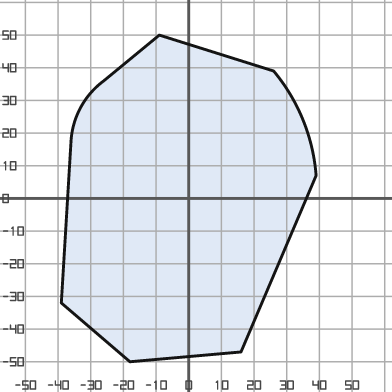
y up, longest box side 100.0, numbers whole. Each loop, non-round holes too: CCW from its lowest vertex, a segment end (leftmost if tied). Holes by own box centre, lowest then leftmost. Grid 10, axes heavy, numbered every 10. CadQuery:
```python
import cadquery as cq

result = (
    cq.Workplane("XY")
    .moveTo(-18.0, -50.0)
    .lineTo(16.0, -47.0)
    .lineTo(39.0, 7.0)
    .threePointArc((35.0, 24.0), (26.0, 39.0))
    .lineTo(-9.0, 50.0)
    .lineTo(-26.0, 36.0)
    .threePointArc((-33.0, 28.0), (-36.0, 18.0))
    .lineTo(-39.0, -32.0)
    .close()
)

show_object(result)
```